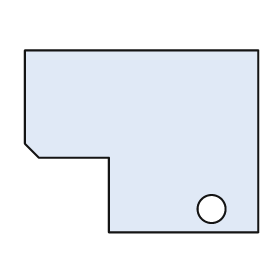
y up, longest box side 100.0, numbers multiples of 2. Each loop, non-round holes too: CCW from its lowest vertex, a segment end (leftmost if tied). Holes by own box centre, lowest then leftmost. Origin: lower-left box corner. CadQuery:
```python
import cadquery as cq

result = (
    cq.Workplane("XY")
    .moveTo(36.0, 0.0)
    .lineTo(100.0, 0.0)
    .lineTo(100.0, 78.0)
    .lineTo(0.0, 78.0)
    .lineTo(0.0, 38.0)
    .lineTo(6.0, 32.0)
    .lineTo(36.0, 32.0)
    .close()
    .moveTo(80.0, 10.0)
    .circle(6.0)
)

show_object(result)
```